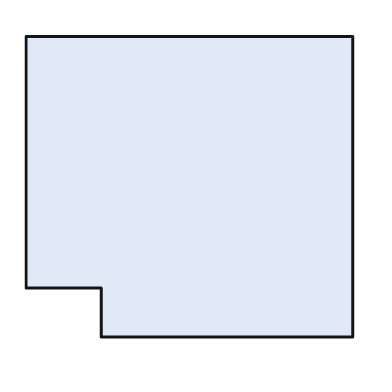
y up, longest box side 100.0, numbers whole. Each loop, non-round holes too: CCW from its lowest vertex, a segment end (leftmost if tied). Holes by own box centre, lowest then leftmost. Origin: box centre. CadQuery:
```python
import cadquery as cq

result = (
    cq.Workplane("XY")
    .moveTo(-27.0, -46.0)
    .lineTo(50.0, -46.0)
    .lineTo(50.0, 46.0)
    .lineTo(-50.0, 46.0)
    .lineTo(-50.0, -31.0)
    .lineTo(-27.0, -31.0)
    .close()
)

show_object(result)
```